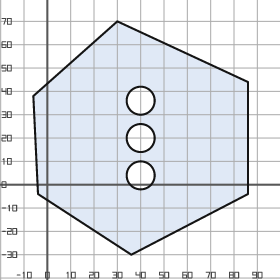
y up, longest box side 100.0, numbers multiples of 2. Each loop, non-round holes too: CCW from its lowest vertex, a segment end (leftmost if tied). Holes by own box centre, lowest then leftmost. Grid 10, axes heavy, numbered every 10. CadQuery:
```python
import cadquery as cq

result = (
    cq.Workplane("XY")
    .moveTo(36.0, -30.0)
    .lineTo(86.0, -4.0)
    .lineTo(86.0, 44.0)
    .lineTo(30.0, 70.0)
    .lineTo(-6.0, 38.0)
    .lineTo(-4.0, -4.0)
    .close()
    .moveTo(40.0, 4.0)
    .circle(6.0)
    .moveTo(40.0, 20.0)
    .circle(6.0)
    .moveTo(40.0, 36.0)
    .circle(6.0)
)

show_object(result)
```